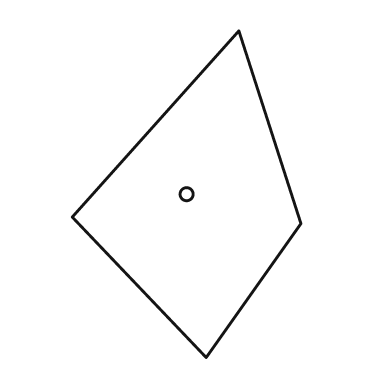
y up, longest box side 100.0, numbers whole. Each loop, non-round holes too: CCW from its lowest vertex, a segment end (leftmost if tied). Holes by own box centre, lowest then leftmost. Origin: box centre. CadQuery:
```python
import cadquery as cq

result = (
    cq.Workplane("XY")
    .moveTo(6.0, -50.0)
    .lineTo(35.0, -9.0)
    .lineTo(16.0, 50.0)
    .lineTo(-35.0, -7.0)
    .close()
    .moveTo(0.0, 0.0)
    .circle(2.0)
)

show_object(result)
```